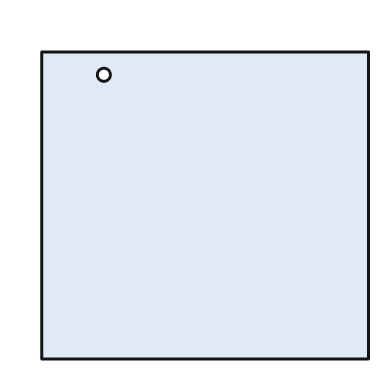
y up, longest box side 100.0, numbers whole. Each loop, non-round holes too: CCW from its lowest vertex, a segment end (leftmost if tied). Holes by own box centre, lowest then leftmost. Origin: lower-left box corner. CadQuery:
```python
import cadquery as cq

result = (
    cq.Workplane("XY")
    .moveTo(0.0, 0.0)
    .lineTo(100.0, 0.0)
    .lineTo(100.0, 94.0)
    .lineTo(0.0, 94.0)
    .close()
    .moveTo(19.0, 87.0)
    .circle(2.0)
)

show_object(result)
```